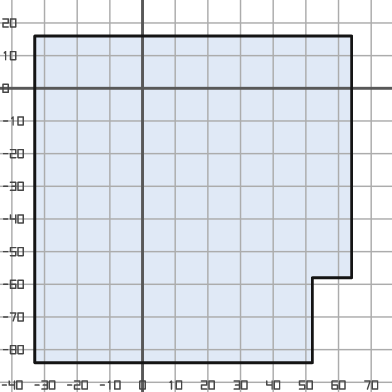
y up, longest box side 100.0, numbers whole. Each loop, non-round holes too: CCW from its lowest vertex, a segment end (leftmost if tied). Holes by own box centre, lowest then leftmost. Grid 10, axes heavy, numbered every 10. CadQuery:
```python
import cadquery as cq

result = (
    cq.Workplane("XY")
    .moveTo(-33.0, -84.0)
    .lineTo(52.0, -84.0)
    .lineTo(52.0, -58.0)
    .lineTo(64.0, -58.0)
    .lineTo(64.0, 16.0)
    .lineTo(-33.0, 16.0)
    .close()
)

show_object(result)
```